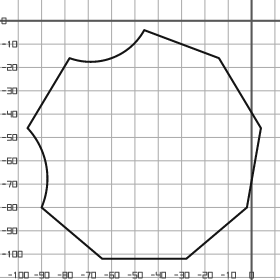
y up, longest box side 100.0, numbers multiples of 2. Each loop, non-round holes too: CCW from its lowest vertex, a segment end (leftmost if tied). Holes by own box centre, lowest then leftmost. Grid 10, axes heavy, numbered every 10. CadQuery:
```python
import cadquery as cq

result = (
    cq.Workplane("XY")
    .moveTo(-64.0, -102.0)
    .lineTo(-28.0, -102.0)
    .lineTo(-2.0, -80.0)
    .lineTo(4.0, -46.0)
    .lineTo(-14.0, -16.0)
    .lineTo(-46.0, -4.0)
    .threePointArc((-60.0, -16.0), (-78.0, -16.0))
    .lineTo(-96.0, -46.0)
    .threePointArc((-88.0, -62.0), (-90.0, -80.0))
    .close()
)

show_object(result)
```